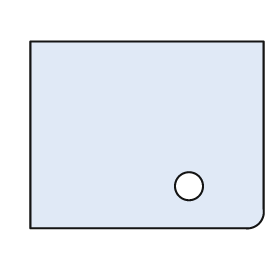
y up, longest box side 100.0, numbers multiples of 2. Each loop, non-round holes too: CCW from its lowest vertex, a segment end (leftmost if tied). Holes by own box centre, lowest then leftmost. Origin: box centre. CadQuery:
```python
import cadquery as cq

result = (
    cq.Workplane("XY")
    .moveTo(-50.0, -40.0)
    .lineTo(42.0, -40.0)
    .threePointArc((48.0, -38.0), (50.0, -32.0))
    .lineTo(50.0, 40.0)
    .lineTo(-50.0, 40.0)
    .close()
    .moveTo(18.0, -22.0)
    .circle(6.0)
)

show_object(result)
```